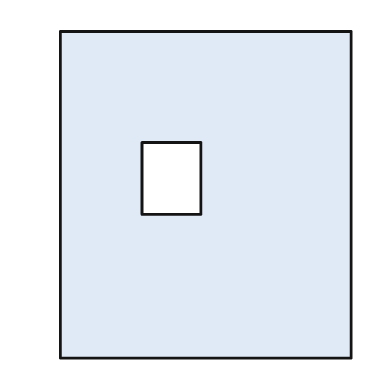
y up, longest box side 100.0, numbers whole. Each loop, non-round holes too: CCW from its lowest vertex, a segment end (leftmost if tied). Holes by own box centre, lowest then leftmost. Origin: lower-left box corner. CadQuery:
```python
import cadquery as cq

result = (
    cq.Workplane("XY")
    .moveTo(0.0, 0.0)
    .lineTo(89.0, 0.0)
    .lineTo(89.0, 100.0)
    .lineTo(0.0, 100.0)
    .close()
    .moveTo(25.0, 44.0)
    .lineTo(43.0, 44.0)
    .lineTo(43.0, 66.0)
    .lineTo(25.0, 66.0)
    .close()
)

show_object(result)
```